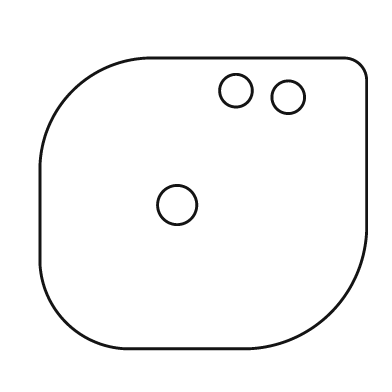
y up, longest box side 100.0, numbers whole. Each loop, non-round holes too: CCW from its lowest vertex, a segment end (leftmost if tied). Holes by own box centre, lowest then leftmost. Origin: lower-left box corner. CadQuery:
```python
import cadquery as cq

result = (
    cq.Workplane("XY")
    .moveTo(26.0, 0.0)
    .lineTo(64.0, 0.0)
    .threePointArc((89.0, 11.0), (100.0, 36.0))
    .lineTo(100.0, 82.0)
    .threePointArc((98.0, 87.0), (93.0, 89.0))
    .lineTo(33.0, 89.0)
    .threePointArc((10.0, 79.0), (0.0, 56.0))
    .lineTo(0.0, 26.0)
    .threePointArc((8.0, 8.0), (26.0, 0.0))
    .close()
    .moveTo(42.0, 44.0)
    .circle(6.0)
    .moveTo(76.0, 77.0)
    .circle(5.0)
    .moveTo(60.0, 79.0)
    .circle(5.0)
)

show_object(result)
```